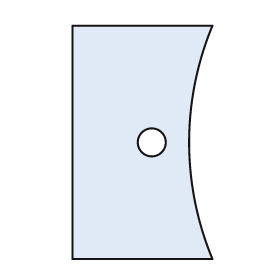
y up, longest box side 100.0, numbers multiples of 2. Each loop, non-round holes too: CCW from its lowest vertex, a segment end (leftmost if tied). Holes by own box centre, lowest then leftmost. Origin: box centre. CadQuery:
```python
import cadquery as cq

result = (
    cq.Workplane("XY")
    .moveTo(-30.0, -50.0)
    .lineTo(30.0, -50.0)
    .threePointArc((20.0, 0.0), (30.0, 50.0))
    .lineTo(-30.0, 50.0)
    .close()
    .moveTo(4.0, 0.0)
    .circle(6.0)
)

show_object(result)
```